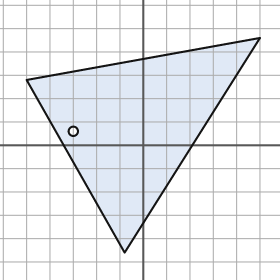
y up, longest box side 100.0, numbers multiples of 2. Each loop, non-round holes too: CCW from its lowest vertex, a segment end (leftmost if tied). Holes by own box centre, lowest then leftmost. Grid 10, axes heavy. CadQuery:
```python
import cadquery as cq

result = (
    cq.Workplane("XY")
    .moveTo(-8.0, -46.0)
    .lineTo(50.0, 46.0)
    .lineTo(-50.0, 28.0)
    .close()
    .moveTo(-30.0, 6.0)
    .circle(2.0)
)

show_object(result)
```